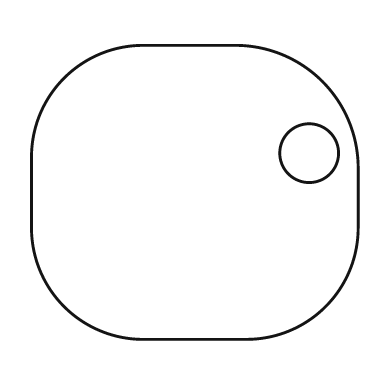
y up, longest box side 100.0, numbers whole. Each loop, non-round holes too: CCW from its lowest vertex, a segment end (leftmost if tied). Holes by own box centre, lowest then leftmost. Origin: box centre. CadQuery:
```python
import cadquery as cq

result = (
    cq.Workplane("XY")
    .moveTo(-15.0, -45.0)
    .lineTo(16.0, -45.0)
    .threePointArc((40.0, -35.0), (50.0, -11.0))
    .lineTo(50.0, 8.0)
    .threePointArc((39.0, 34.0), (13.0, 45.0))
    .lineTo(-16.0, 45.0)
    .threePointArc((-40.0, 35.0), (-50.0, 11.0))
    .lineTo(-50.0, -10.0)
    .threePointArc((-40.0, -35.0), (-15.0, -45.0))
    .close()
    .moveTo(35.0, 12.0)
    .circle(9.0)
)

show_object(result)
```